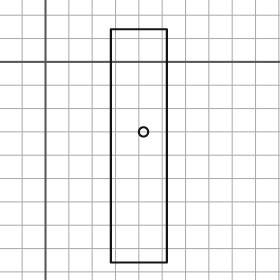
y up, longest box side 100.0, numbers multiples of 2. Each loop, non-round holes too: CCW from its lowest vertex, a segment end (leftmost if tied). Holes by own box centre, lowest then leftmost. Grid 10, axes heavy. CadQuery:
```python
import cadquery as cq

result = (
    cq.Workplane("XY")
    .moveTo(28.0, -86.0)
    .lineTo(52.0, -86.0)
    .lineTo(52.0, 14.0)
    .lineTo(28.0, 14.0)
    .close()
    .moveTo(42.0, -30.0)
    .circle(2.0)
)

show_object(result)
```